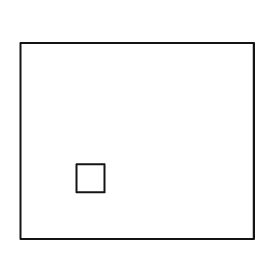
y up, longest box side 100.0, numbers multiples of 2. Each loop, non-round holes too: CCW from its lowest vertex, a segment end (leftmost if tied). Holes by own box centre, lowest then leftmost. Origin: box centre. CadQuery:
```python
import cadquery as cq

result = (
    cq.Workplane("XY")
    .moveTo(-50.0, -42.0)
    .lineTo(50.0, -42.0)
    .lineTo(50.0, 42.0)
    .lineTo(-50.0, 42.0)
    .close()
    .moveTo(-26.0, -22.0)
    .lineTo(-14.0, -22.0)
    .lineTo(-14.0, -10.0)
    .lineTo(-26.0, -10.0)
    .close()
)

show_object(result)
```